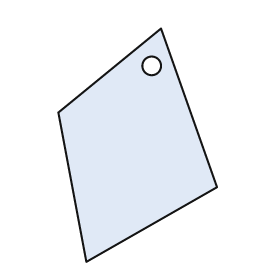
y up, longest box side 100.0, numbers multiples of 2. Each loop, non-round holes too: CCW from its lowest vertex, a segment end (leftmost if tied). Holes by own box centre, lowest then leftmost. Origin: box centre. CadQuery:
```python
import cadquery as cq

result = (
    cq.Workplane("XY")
    .moveTo(-22.0, -50.0)
    .lineTo(34.0, -18.0)
    .lineTo(10.0, 50.0)
    .lineTo(-34.0, 14.0)
    .close()
    .moveTo(6.0, 34.0)
    .circle(4.0)
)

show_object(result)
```